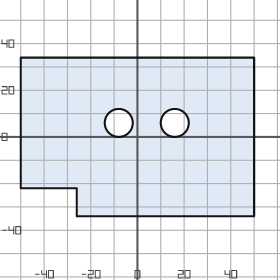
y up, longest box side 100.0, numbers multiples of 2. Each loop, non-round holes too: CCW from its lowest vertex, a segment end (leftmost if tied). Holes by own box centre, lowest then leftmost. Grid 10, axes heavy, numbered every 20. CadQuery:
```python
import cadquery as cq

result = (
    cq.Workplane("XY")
    .moveTo(-26.0, -34.0)
    .lineTo(50.0, -34.0)
    .lineTo(50.0, 34.0)
    .lineTo(-50.0, 34.0)
    .lineTo(-50.0, -22.0)
    .lineTo(-26.0, -22.0)
    .close()
    .moveTo(-8.0, 6.0)
    .circle(6.0)
    .moveTo(16.0, 6.0)
    .circle(6.0)
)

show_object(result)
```